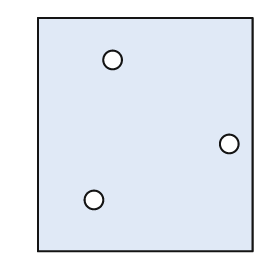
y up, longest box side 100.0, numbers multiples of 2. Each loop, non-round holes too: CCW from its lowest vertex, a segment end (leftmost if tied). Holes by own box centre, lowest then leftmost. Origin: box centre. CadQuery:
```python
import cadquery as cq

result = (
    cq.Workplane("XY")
    .moveTo(-46.0, -50.0)
    .lineTo(46.0, -50.0)
    .lineTo(46.0, 50.0)
    .lineTo(-46.0, 50.0)
    .close()
    .moveTo(-22.0, -28.0)
    .circle(4.0)
    .moveTo(36.0, -4.0)
    .circle(4.0)
    .moveTo(-14.0, 32.0)
    .circle(4.0)
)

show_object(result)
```